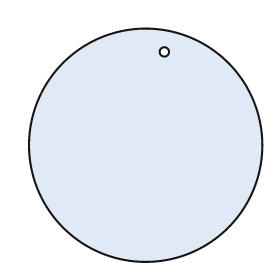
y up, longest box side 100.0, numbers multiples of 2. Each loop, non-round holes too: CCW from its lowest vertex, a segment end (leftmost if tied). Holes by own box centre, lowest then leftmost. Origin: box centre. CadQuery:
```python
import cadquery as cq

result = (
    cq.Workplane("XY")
    .moveTo(0.0, 0.0)
    .circle(50.0)
    .moveTo(8.0, 40.0)
    .circle(2.0)
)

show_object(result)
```